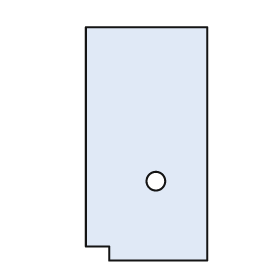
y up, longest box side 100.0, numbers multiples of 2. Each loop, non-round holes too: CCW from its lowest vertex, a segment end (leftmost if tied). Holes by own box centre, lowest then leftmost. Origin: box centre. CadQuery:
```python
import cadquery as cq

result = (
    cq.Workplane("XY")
    .moveTo(-16.0, -50.0)
    .lineTo(26.0, -50.0)
    .lineTo(26.0, 50.0)
    .lineTo(-26.0, 50.0)
    .lineTo(-26.0, -44.0)
    .lineTo(-16.0, -44.0)
    .close()
    .moveTo(4.0, -16.0)
    .circle(4.0)
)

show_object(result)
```